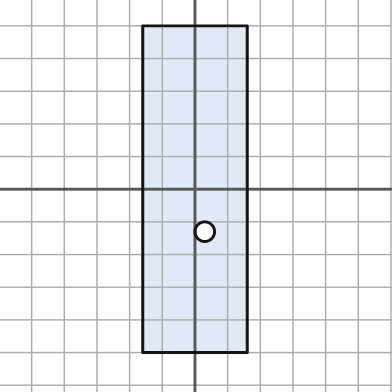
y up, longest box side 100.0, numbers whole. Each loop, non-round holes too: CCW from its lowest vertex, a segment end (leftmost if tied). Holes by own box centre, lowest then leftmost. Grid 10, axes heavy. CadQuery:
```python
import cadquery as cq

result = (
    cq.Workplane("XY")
    .moveTo(-16.0, -50.0)
    .lineTo(16.0, -50.0)
    .lineTo(16.0, 50.0)
    .lineTo(-16.0, 50.0)
    .close()
    .moveTo(3.0, -13.0)
    .circle(3.0)
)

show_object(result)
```